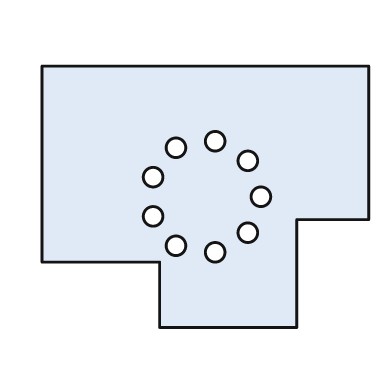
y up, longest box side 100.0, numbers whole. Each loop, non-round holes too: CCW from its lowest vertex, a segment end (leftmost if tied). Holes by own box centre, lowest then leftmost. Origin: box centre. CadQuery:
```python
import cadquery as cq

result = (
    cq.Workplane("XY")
    .moveTo(-14.0, -40.0)
    .lineTo(28.0, -40.0)
    .lineTo(28.0, -7.0)
    .lineTo(50.0, -7.0)
    .lineTo(50.0, 40.0)
    .lineTo(-50.0, 40.0)
    .lineTo(-50.0, -20.0)
    .lineTo(-14.0, -20.0)
    .close()
    .moveTo(3.0, -17.0)
    .circle(3.0)
    .moveTo(-9.0, -15.0)
    .circle(3.0)
    .moveTo(13.0, -11.0)
    .circle(3.0)
    .moveTo(-16.0, -6.0)
    .circle(3.0)
    .moveTo(17.0, 0.0)
    .circle(3.0)
    .moveTo(-16.0, 6.0)
    .circle(3.0)
    .moveTo(13.0, 11.0)
    .circle(3.0)
    .moveTo(-9.0, 15.0)
    .circle(3.0)
    .moveTo(3.0, 17.0)
    .circle(3.0)
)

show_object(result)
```